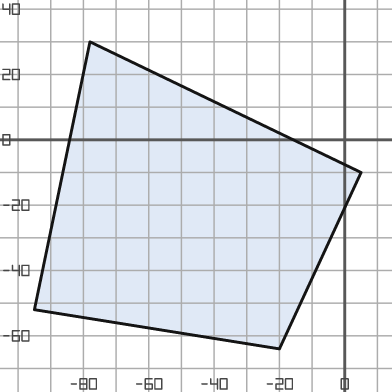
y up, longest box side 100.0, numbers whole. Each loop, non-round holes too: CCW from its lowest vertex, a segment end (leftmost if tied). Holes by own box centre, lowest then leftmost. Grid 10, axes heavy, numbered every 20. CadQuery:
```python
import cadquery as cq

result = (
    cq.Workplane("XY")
    .moveTo(-20.0, -64.0)
    .lineTo(5.0, -10.0)
    .lineTo(-78.0, 30.0)
    .lineTo(-95.0, -52.0)
    .close()
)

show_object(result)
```